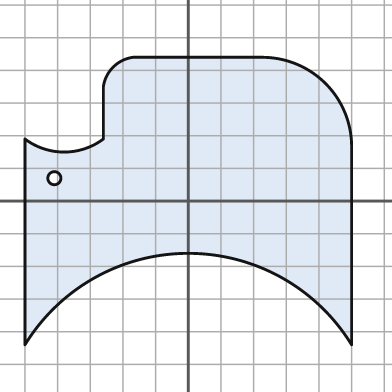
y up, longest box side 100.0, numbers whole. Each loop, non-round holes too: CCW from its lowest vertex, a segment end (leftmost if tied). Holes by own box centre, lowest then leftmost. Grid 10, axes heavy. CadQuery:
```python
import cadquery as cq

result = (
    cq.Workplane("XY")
    .moveTo(-50.0, -44.0)
    .threePointArc((0.0, -16.0), (50.0, -44.0))
    .lineTo(50.0, 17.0)
    .threePointArc((42.0, 36.0), (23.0, 44.0))
    .lineTo(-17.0, 44.0)
    .threePointArc((-23.0, 41.0), (-26.0, 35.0))
    .lineTo(-26.0, 19.0)
    .threePointArc((-38.0, 15.0), (-50.0, 19.0))
    .close()
    .moveTo(-41.0, 7.0)
    .circle(2.0)
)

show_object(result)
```